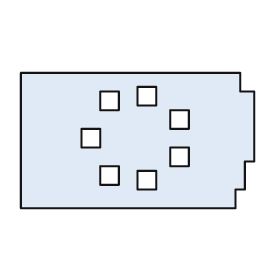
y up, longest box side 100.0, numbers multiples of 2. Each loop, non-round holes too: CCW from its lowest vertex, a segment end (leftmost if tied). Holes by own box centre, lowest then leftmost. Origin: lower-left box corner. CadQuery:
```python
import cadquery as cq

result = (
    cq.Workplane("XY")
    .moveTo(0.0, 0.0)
    .lineTo(92.0, 0.0)
    .lineTo(92.0, 8.0)
    .lineTo(96.0, 8.0)
    .lineTo(96.0, 20.0)
    .lineTo(100.0, 20.0)
    .lineTo(100.0, 50.0)
    .lineTo(94.0, 50.0)
    .lineTo(94.0, 58.0)
    .lineTo(0.0, 58.0)
    .close()
    .moveTo(50.0, 8.0)
    .lineTo(58.0, 8.0)
    .lineTo(58.0, 16.0)
    .lineTo(50.0, 16.0)
    .close()
    .moveTo(34.0, 10.0)
    .lineTo(42.0, 10.0)
    .lineTo(42.0, 18.0)
    .lineTo(34.0, 18.0)
    .close()
    .moveTo(64.0, 18.0)
    .lineTo(72.0, 18.0)
    .lineTo(72.0, 26.0)
    .lineTo(64.0, 26.0)
    .close()
    .moveTo(26.0, 26.0)
    .lineTo(34.0, 26.0)
    .lineTo(34.0, 34.0)
    .lineTo(26.0, 34.0)
    .close()
    .moveTo(64.0, 34.0)
    .lineTo(72.0, 34.0)
    .lineTo(72.0, 42.0)
    .lineTo(64.0, 42.0)
    .close()
    .moveTo(34.0, 42.0)
    .lineTo(42.0, 42.0)
    .lineTo(42.0, 50.0)
    .lineTo(34.0, 50.0)
    .close()
    .moveTo(50.0, 44.0)
    .lineTo(58.0, 44.0)
    .lineTo(58.0, 52.0)
    .lineTo(50.0, 52.0)
    .close()
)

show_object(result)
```